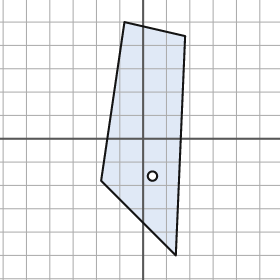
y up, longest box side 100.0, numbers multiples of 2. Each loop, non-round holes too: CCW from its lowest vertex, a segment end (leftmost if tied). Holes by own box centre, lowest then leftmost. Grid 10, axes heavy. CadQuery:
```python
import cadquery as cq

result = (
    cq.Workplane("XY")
    .moveTo(14.0, -50.0)
    .lineTo(18.0, 44.0)
    .lineTo(-8.0, 50.0)
    .lineTo(-18.0, -18.0)
    .close()
    .moveTo(4.0, -16.0)
    .circle(2.0)
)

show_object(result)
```